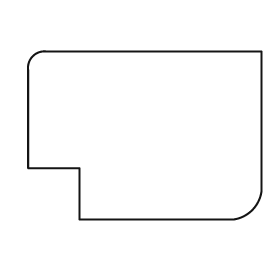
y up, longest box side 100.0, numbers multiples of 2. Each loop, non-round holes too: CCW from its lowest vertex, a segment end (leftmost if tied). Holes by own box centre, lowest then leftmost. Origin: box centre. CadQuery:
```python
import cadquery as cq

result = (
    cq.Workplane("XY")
    .moveTo(-28.0, -36.0)
    .lineTo(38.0, -36.0)
    .threePointArc((46.0, -32.0), (50.0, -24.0))
    .lineTo(50.0, 36.0)
    .lineTo(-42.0, 36.0)
    .threePointArc((-48.0, 34.0), (-50.0, 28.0))
    .lineTo(-50.0, -14.0)
    .lineTo(-28.0, -14.0)
    .close()
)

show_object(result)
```